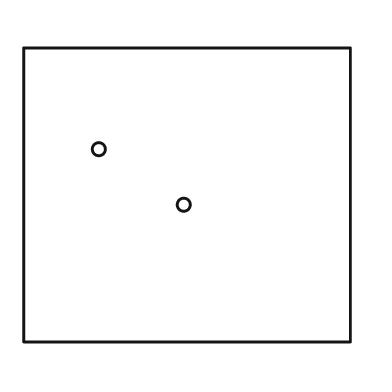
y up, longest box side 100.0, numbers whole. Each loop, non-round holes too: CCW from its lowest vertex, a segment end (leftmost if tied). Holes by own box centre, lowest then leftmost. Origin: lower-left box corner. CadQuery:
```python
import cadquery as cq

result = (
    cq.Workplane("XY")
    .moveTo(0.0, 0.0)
    .lineTo(100.0, 0.0)
    .lineTo(100.0, 90.0)
    .lineTo(0.0, 90.0)
    .close()
    .moveTo(49.0, 42.0)
    .circle(2.0)
    .moveTo(23.0, 59.0)
    .circle(2.0)
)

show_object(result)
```